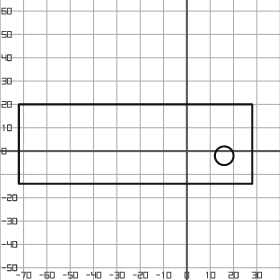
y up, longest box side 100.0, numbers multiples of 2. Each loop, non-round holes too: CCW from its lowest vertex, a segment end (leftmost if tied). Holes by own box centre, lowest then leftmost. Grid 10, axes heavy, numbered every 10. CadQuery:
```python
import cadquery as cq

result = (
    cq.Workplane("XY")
    .moveTo(-72.0, -14.0)
    .lineTo(28.0, -14.0)
    .lineTo(28.0, 20.0)
    .lineTo(-72.0, 20.0)
    .close()
    .moveTo(16.0, -2.0)
    .circle(4.0)
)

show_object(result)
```